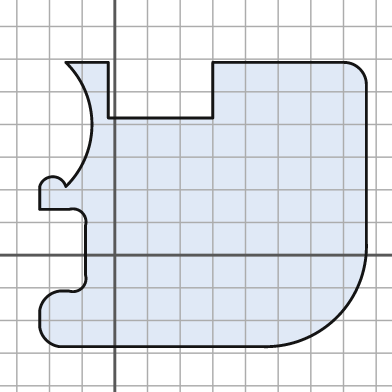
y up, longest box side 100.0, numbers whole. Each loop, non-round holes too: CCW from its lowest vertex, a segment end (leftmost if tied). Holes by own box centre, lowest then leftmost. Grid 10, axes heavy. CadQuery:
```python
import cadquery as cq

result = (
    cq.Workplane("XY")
    .moveTo(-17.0, -28.0)
    .lineTo(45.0, -28.0)
    .threePointArc((68.0, -19.0), (77.0, 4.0))
    .lineTo(77.0, 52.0)
    .threePointArc((75.0, 57.0), (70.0, 59.0))
    .lineTo(30.0, 59.0)
    .lineTo(30.0, 42.0)
    .lineTo(-2.0, 42.0)
    .lineTo(-2.0, 59.0)
    .lineTo(-15.0, 59.0)
    .threePointArc((-7.0, 40.0), (-15.0, 21.0))
    .threePointArc((-19.0, 24.0), (-23.0, 21.0))
    .lineTo(-23.0, 14.0)
    .lineTo(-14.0, 14.0)
    .threePointArc((-10.0, 13.0), (-9.0, 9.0))
    .lineTo(-9.0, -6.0)
    .threePointArc((-10.0, -10.0), (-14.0, -11.0))
    .lineTo(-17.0, -11.0)
    .threePointArc((-21.0, -13.0), (-23.0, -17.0))
    .lineTo(-23.0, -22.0)
    .threePointArc((-21.0, -26.0), (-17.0, -28.0))
    .close()
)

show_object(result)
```